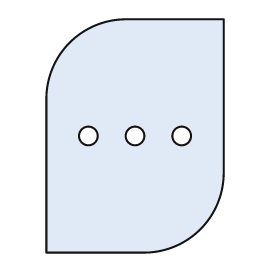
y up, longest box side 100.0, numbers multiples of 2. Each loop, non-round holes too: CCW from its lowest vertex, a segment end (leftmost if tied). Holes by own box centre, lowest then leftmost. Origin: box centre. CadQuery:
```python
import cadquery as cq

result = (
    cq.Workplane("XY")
    .moveTo(-38.0, -50.0)
    .lineTo(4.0, -50.0)
    .threePointArc((28.0, -40.0), (38.0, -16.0))
    .lineTo(38.0, 50.0)
    .lineTo(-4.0, 50.0)
    .threePointArc((-28.0, 40.0), (-38.0, 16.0))
    .close()
    .moveTo(-20.0, 0.0)
    .circle(4.0)
    .moveTo(0.0, 0.0)
    .circle(4.0)
    .moveTo(20.0, 0.0)
    .circle(4.0)
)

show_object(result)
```